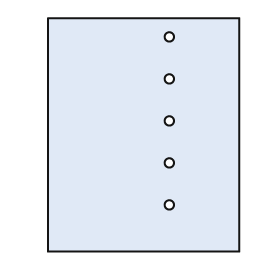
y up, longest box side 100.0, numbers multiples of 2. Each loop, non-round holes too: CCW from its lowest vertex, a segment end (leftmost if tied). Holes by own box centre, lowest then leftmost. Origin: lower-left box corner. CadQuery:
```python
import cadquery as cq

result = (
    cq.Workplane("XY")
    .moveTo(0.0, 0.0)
    .lineTo(82.0, 0.0)
    .lineTo(82.0, 100.0)
    .lineTo(0.0, 100.0)
    .close()
    .moveTo(52.0, 20.0)
    .circle(2.0)
    .moveTo(52.0, 38.0)
    .circle(2.0)
    .moveTo(52.0, 56.0)
    .circle(2.0)
    .moveTo(52.0, 74.0)
    .circle(2.0)
    .moveTo(52.0, 92.0)
    .circle(2.0)
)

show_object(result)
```